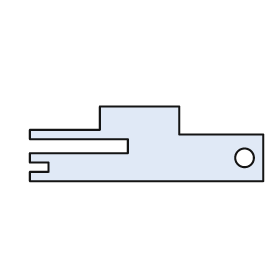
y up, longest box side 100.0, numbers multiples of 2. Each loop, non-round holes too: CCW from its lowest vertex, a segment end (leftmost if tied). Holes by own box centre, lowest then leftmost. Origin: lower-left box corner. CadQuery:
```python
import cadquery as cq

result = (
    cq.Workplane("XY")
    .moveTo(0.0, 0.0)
    .lineTo(100.0, 0.0)
    .lineTo(100.0, 20.0)
    .lineTo(64.0, 20.0)
    .lineTo(64.0, 32.0)
    .lineTo(30.0, 32.0)
    .lineTo(30.0, 22.0)
    .lineTo(0.0, 22.0)
    .lineTo(0.0, 18.0)
    .lineTo(42.0, 18.0)
    .lineTo(42.0, 12.0)
    .lineTo(0.0, 12.0)
    .lineTo(0.0, 8.0)
    .lineTo(8.0, 8.0)
    .lineTo(8.0, 4.0)
    .lineTo(0.0, 4.0)
    .close()
    .moveTo(92.0, 10.0)
    .circle(4.0)
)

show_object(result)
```